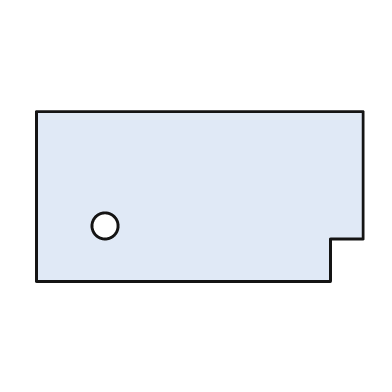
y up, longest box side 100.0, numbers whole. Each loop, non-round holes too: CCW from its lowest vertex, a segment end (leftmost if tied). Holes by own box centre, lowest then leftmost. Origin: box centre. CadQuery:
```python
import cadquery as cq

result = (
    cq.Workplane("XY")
    .moveTo(-50.0, -26.0)
    .lineTo(40.0, -26.0)
    .lineTo(40.0, -13.0)
    .lineTo(50.0, -13.0)
    .lineTo(50.0, 26.0)
    .lineTo(-50.0, 26.0)
    .close()
    .moveTo(-29.0, -9.0)
    .circle(4.0)
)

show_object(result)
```